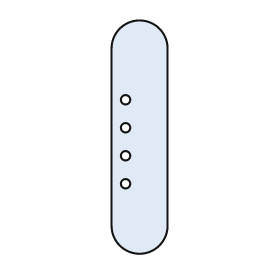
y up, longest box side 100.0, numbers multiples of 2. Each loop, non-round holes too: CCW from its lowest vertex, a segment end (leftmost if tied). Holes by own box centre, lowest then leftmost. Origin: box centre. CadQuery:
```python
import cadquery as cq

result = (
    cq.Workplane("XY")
    .moveTo(-12.0, -38.0)
    .threePointArc((0.0, -50.0), (12.0, -38.0))
    .lineTo(12.0, 38.0)
    .threePointArc((0.0, 50.0), (-12.0, 38.0))
    .close()
    .moveTo(-6.0, -20.0)
    .circle(2.0)
    .moveTo(-6.0, -8.0)
    .circle(2.0)
    .moveTo(-6.0, 4.0)
    .circle(2.0)
    .moveTo(-6.0, 16.0)
    .circle(2.0)
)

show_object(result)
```